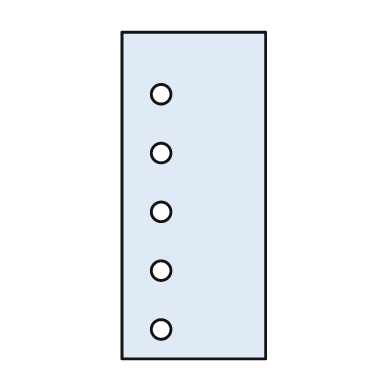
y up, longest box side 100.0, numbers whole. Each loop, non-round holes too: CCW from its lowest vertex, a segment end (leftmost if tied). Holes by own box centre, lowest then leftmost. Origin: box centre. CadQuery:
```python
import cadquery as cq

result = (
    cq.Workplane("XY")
    .moveTo(-22.0, -50.0)
    .lineTo(22.0, -50.0)
    .lineTo(22.0, 50.0)
    .lineTo(-22.0, 50.0)
    .close()
    .moveTo(-10.0, -41.0)
    .circle(3.0)
    .moveTo(-10.0, -23.0)
    .circle(3.0)
    .moveTo(-10.0, -5.0)
    .circle(3.0)
    .moveTo(-10.0, 13.0)
    .circle(3.0)
    .moveTo(-10.0, 31.0)
    .circle(3.0)
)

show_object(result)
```